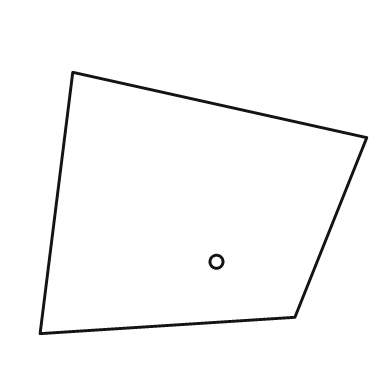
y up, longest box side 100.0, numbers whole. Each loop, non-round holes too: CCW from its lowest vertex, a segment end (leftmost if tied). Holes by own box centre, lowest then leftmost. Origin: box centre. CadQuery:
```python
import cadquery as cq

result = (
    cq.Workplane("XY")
    .moveTo(-50.0, -40.0)
    .lineTo(28.0, -35.0)
    .lineTo(50.0, 20.0)
    .lineTo(-40.0, 40.0)
    .close()
    .moveTo(4.0, -18.0)
    .circle(2.0)
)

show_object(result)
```